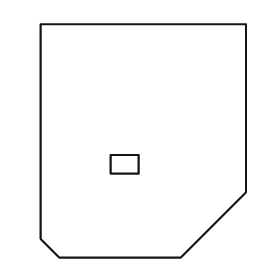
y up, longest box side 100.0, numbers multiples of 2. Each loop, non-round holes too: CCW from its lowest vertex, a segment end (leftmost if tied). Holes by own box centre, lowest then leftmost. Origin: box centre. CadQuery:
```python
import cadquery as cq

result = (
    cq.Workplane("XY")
    .moveTo(-36.0, -50.0)
    .lineTo(16.0, -50.0)
    .lineTo(44.0, -22.0)
    .lineTo(44.0, 50.0)
    .lineTo(-44.0, 50.0)
    .lineTo(-44.0, -42.0)
    .close()
    .moveTo(-14.0, -14.0)
    .lineTo(-2.0, -14.0)
    .lineTo(-2.0, -6.0)
    .lineTo(-14.0, -6.0)
    .close()
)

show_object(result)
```